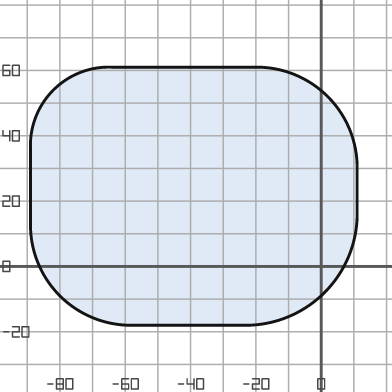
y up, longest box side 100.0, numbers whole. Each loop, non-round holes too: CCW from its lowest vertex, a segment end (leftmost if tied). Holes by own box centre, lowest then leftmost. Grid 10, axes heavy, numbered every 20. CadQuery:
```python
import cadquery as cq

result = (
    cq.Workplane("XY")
    .moveTo(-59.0, -18.0)
    .lineTo(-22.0, -18.0)
    .threePointArc((1.0, -8.0), (11.0, 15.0))
    .lineTo(11.0, 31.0)
    .threePointArc((2.0, 52.0), (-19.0, 61.0))
    .lineTo(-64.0, 61.0)
    .threePointArc((-82.0, 54.0), (-89.0, 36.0))
    .lineTo(-89.0, 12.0)
    .threePointArc((-80.0, -9.0), (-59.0, -18.0))
    .close()
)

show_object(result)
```